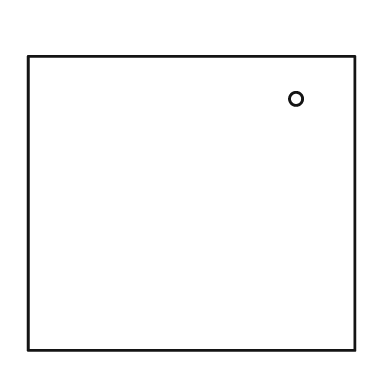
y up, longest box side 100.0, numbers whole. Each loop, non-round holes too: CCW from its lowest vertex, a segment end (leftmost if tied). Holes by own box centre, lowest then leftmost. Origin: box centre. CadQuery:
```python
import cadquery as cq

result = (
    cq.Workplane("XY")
    .moveTo(-50.0, -45.0)
    .lineTo(50.0, -45.0)
    .lineTo(50.0, 45.0)
    .lineTo(-50.0, 45.0)
    .close()
    .moveTo(32.0, 32.0)
    .circle(2.0)
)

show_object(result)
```